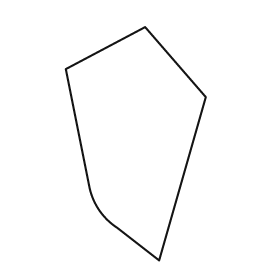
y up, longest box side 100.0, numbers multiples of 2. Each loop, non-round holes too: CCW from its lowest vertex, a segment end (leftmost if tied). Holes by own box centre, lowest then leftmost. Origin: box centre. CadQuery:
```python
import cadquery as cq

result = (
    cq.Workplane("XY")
    .moveTo(10.0, -50.0)
    .lineTo(30.0, 20.0)
    .lineTo(4.0, 50.0)
    .lineTo(-30.0, 32.0)
    .lineTo(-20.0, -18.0)
    .threePointArc((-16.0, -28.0), (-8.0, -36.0))
    .close()
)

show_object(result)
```